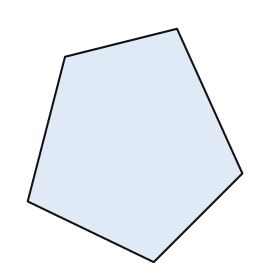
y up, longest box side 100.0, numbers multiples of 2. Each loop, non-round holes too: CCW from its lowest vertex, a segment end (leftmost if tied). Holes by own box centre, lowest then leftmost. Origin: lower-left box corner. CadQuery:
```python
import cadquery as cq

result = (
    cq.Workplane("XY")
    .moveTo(54.0, 0.0)
    .lineTo(92.0, 38.0)
    .lineTo(64.0, 100.0)
    .lineTo(16.0, 88.0)
    .lineTo(0.0, 26.0)
    .close()
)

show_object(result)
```